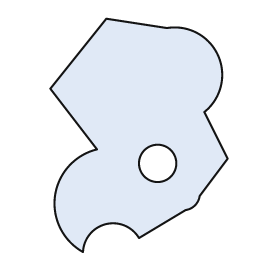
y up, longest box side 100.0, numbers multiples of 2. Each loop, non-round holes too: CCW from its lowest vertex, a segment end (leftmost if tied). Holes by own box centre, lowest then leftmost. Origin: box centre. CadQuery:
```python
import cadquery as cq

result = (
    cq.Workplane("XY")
    .moveTo(-24.0, -50.0)
    .threePointArc((-14.0, -38.0), (0.0, -44.0))
    .lineTo(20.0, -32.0)
    .threePointArc((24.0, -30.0), (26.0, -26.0))
    .lineTo(38.0, -10.0)
    .lineTo(28.0, 10.0)
    .threePointArc((34.0, 34.0), (12.0, 46.0))
    .lineTo(-14.0, 50.0)
    .lineTo(-38.0, 20.0)
    .lineTo(-18.0, -6.0)
    .threePointArc((-36.0, -26.0), (-24.0, -50.0))
    .close()
    .moveTo(8.0, -12.0)
    .circle(8.0)
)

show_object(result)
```